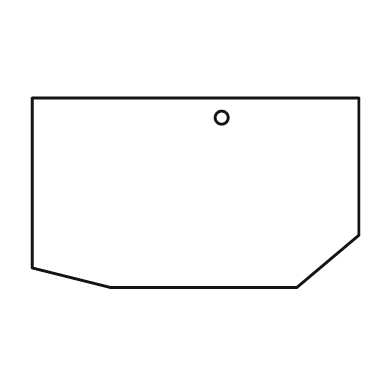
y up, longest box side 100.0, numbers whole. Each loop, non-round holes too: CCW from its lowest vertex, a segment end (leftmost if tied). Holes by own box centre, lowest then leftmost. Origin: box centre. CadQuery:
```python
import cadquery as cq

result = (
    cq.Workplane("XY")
    .moveTo(-26.0, -29.0)
    .lineTo(31.0, -29.0)
    .lineTo(50.0, -13.0)
    .lineTo(50.0, 29.0)
    .lineTo(-50.0, 29.0)
    .lineTo(-50.0, -23.0)
    .close()
    .moveTo(8.0, 23.0)
    .circle(2.0)
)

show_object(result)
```